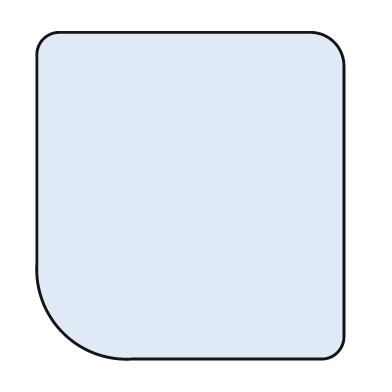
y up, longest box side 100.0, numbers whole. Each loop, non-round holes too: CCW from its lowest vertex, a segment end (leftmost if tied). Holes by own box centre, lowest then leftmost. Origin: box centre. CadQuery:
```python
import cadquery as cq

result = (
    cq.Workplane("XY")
    .moveTo(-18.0, -50.0)
    .lineTo(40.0, -50.0)
    .threePointArc((45.0, -48.0), (47.0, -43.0))
    .lineTo(47.0, 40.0)
    .threePointArc((44.0, 47.0), (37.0, 50.0))
    .lineTo(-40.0, 50.0)
    .threePointArc((-45.0, 48.0), (-47.0, 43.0))
    .lineTo(-47.0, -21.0)
    .threePointArc((-39.0, -42.0), (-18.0, -50.0))
    .close()
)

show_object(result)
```